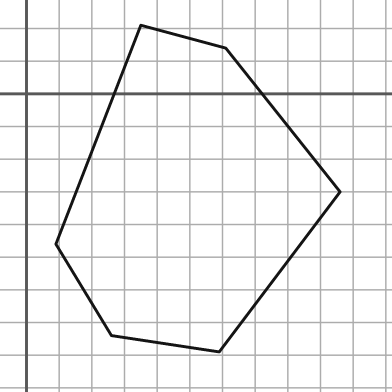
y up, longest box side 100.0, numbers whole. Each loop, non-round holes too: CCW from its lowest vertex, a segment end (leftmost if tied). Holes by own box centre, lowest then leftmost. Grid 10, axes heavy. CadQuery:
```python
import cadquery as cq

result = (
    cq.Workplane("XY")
    .moveTo(59.0, -79.0)
    .lineTo(96.0, -30.0)
    .lineTo(61.0, 14.0)
    .lineTo(35.0, 21.0)
    .lineTo(9.0, -46.0)
    .lineTo(26.0, -74.0)
    .close()
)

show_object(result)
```